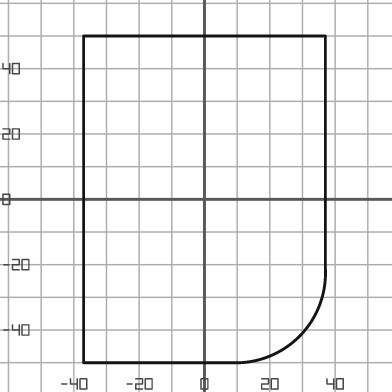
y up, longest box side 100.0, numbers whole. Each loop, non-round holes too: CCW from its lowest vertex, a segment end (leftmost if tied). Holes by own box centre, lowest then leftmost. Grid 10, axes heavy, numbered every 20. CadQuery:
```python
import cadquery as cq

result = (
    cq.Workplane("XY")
    .moveTo(-37.0, -50.0)
    .lineTo(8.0, -50.0)
    .threePointArc((29.0, -42.0), (37.0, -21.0))
    .lineTo(37.0, 50.0)
    .lineTo(-37.0, 50.0)
    .close()
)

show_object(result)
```